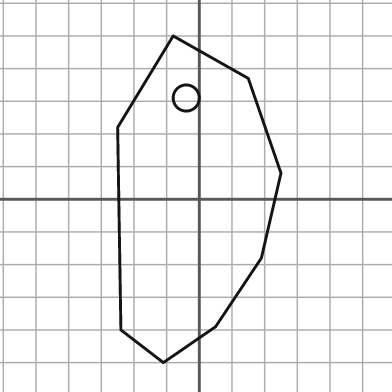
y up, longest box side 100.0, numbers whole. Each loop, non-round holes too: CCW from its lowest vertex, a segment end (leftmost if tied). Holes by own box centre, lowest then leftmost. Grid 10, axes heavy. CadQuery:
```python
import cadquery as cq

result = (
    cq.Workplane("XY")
    .moveTo(-11.0, -50.0)
    .lineTo(5.0, -39.0)
    .lineTo(19.0, -18.0)
    .lineTo(25.0, 8.0)
    .lineTo(15.0, 37.0)
    .lineTo(-8.0, 50.0)
    .lineTo(-25.0, 22.0)
    .lineTo(-24.0, -40.0)
    .close()
    .moveTo(-4.0, 31.0)
    .circle(4.0)
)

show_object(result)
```